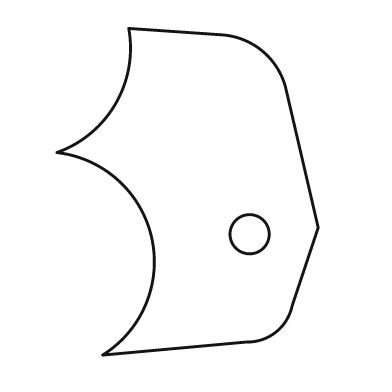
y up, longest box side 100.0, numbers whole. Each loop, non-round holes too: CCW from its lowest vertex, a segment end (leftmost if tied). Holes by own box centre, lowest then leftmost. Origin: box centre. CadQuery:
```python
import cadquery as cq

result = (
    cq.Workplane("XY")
    .moveTo(-26.0, -50.0)
    .lineTo(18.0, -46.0)
    .threePointArc((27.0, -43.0), (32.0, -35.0))
    .lineTo(40.0, -11.0)
    .lineTo(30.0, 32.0)
    .threePointArc((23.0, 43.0), (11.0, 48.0))
    .lineTo(-18.0, 50.0)
    .threePointArc((-22.0, 27.0), (-40.0, 12.0))
    .threePointArc((-11.0, -14.0), (-26.0, -50.0))
    .close()
    .moveTo(19.0, -13.0)
    .circle(6.0)
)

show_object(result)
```